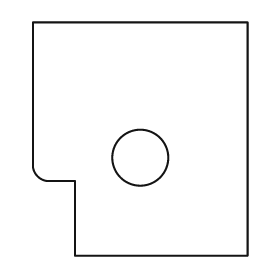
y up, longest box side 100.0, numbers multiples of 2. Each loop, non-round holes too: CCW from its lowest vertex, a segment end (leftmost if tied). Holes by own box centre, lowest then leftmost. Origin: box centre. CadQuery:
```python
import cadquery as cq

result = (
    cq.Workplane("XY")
    .moveTo(-28.0, -50.0)
    .lineTo(46.0, -50.0)
    .lineTo(46.0, 50.0)
    .lineTo(-46.0, 50.0)
    .lineTo(-46.0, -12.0)
    .threePointArc((-44.0, -16.0), (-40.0, -18.0))
    .lineTo(-28.0, -18.0)
    .close()
    .moveTo(0.0, -8.0)
    .circle(12.0)
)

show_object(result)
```